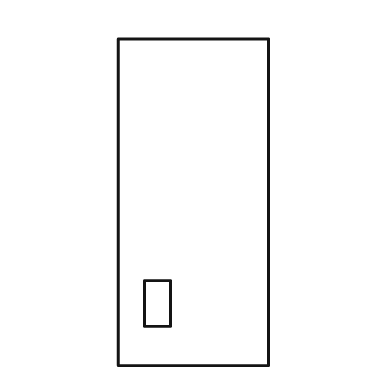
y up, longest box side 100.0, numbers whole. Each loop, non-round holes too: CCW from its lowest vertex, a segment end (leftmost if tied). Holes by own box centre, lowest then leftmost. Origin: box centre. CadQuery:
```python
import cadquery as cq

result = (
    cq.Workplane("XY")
    .moveTo(-23.0, -50.0)
    .lineTo(23.0, -50.0)
    .lineTo(23.0, 50.0)
    .lineTo(-23.0, 50.0)
    .close()
    .moveTo(-15.0, -38.0)
    .lineTo(-7.0, -38.0)
    .lineTo(-7.0, -24.0)
    .lineTo(-15.0, -24.0)
    .close()
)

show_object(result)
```